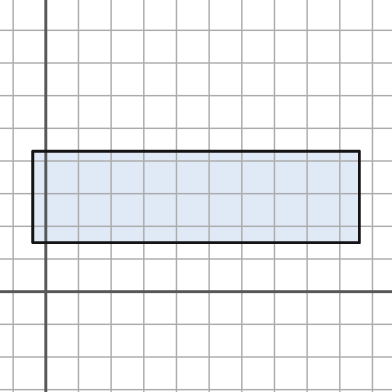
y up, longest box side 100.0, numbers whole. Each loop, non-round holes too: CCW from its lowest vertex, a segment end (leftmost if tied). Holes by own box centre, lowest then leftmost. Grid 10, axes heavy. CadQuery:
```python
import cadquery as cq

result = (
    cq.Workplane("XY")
    .moveTo(-4.0, 15.0)
    .lineTo(96.0, 15.0)
    .lineTo(96.0, 43.0)
    .lineTo(-4.0, 43.0)
    .close()
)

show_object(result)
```